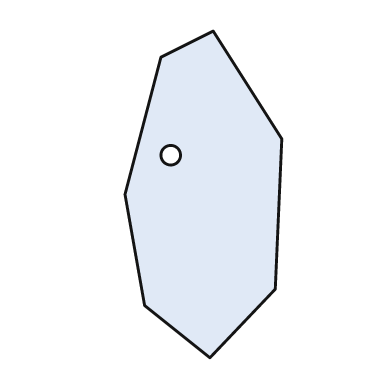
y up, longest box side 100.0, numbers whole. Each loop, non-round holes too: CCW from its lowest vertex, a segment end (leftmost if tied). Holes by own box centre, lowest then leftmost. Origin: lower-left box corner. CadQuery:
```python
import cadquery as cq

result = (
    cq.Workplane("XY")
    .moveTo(26.0, 0.0)
    .lineTo(46.0, 21.0)
    .lineTo(48.0, 67.0)
    .lineTo(27.0, 100.0)
    .lineTo(11.0, 92.0)
    .lineTo(0.0, 50.0)
    .lineTo(6.0, 16.0)
    .close()
    .moveTo(14.0, 62.0)
    .circle(3.0)
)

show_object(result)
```